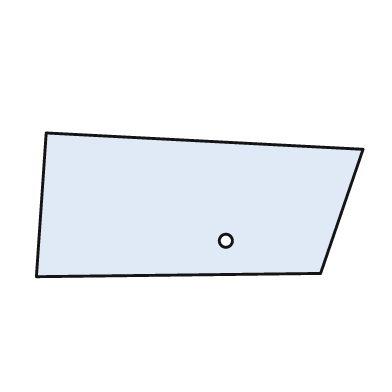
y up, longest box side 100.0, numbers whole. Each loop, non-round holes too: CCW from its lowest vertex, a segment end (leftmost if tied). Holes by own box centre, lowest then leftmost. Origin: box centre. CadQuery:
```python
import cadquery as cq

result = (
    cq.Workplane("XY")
    .moveTo(-50.0, -22.0)
    .lineTo(37.0, -21.0)
    .lineTo(50.0, 17.0)
    .lineTo(-47.0, 22.0)
    .close()
    .moveTo(8.0, -11.0)
    .circle(2.0)
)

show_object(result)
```